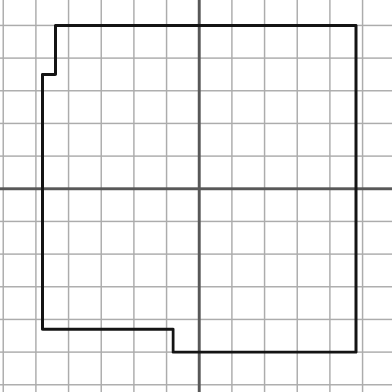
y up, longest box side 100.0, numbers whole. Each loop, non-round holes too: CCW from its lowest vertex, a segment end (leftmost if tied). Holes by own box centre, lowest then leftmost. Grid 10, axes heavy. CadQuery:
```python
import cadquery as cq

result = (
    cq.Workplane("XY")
    .moveTo(-8.0, -50.0)
    .lineTo(48.0, -50.0)
    .lineTo(48.0, 50.0)
    .lineTo(-44.0, 50.0)
    .lineTo(-44.0, 35.0)
    .lineTo(-48.0, 35.0)
    .lineTo(-48.0, -43.0)
    .lineTo(-8.0, -43.0)
    .close()
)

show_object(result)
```